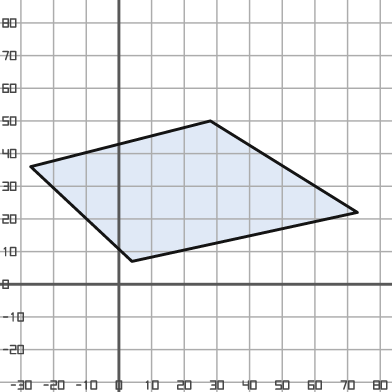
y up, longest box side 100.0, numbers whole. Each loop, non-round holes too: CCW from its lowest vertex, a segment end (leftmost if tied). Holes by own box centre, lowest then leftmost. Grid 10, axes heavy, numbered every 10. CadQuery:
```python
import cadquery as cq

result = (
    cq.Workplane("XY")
    .moveTo(4.0, 7.0)
    .lineTo(73.0, 22.0)
    .lineTo(28.0, 50.0)
    .lineTo(-27.0, 36.0)
    .close()
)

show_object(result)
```